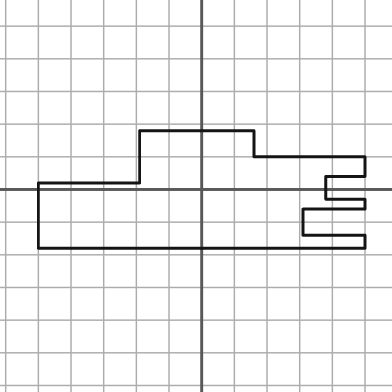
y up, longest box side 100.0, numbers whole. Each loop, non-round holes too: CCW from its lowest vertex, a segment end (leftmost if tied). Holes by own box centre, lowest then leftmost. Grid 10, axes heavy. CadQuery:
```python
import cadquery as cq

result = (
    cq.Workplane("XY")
    .moveTo(-50.0, -18.0)
    .lineTo(50.0, -18.0)
    .lineTo(50.0, -14.0)
    .lineTo(31.0, -14.0)
    .lineTo(31.0, -6.0)
    .lineTo(50.0, -6.0)
    .lineTo(50.0, -3.0)
    .lineTo(38.0, -3.0)
    .lineTo(38.0, 4.0)
    .lineTo(50.0, 4.0)
    .lineTo(50.0, 10.0)
    .lineTo(16.0, 10.0)
    .lineTo(16.0, 18.0)
    .lineTo(-19.0, 18.0)
    .lineTo(-19.0, 2.0)
    .lineTo(-50.0, 2.0)
    .close()
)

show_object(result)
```